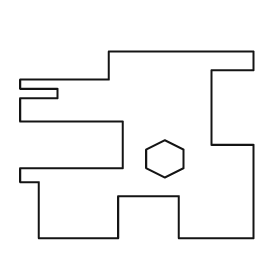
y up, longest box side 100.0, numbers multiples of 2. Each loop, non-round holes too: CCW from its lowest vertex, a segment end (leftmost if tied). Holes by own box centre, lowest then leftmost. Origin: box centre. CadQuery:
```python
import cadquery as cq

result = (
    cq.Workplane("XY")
    .moveTo(-42.0, -40.0)
    .lineTo(-8.0, -40.0)
    .lineTo(-8.0, -22.0)
    .lineTo(18.0, -22.0)
    .lineTo(18.0, -40.0)
    .lineTo(50.0, -40.0)
    .lineTo(50.0, 0.0)
    .lineTo(32.0, 0.0)
    .lineTo(32.0, 32.0)
    .lineTo(50.0, 32.0)
    .lineTo(50.0, 40.0)
    .lineTo(-12.0, 40.0)
    .lineTo(-12.0, 28.0)
    .lineTo(-50.0, 28.0)
    .lineTo(-50.0, 24.0)
    .lineTo(-34.0, 24.0)
    .lineTo(-34.0, 20.0)
    .lineTo(-50.0, 20.0)
    .lineTo(-50.0, 10.0)
    .lineTo(-6.0, 10.0)
    .lineTo(-6.0, -10.0)
    .lineTo(-50.0, -10.0)
    .lineTo(-50.0, -16.0)
    .lineTo(-42.0, -16.0)
    .close()
    .moveTo(12.0, -14.0)
    .lineTo(20.0, -10.0)
    .lineTo(20.0, -2.0)
    .lineTo(12.0, 2.0)
    .lineTo(4.0, -2.0)
    .lineTo(4.0, -10.0)
    .close()
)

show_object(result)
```